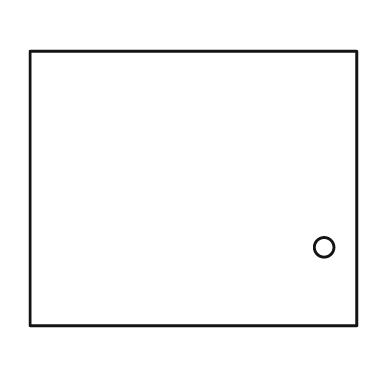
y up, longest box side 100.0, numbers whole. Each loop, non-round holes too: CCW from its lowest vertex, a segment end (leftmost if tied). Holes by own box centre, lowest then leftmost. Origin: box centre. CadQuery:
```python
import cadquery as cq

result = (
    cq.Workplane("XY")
    .moveTo(-50.0, -42.0)
    .lineTo(50.0, -42.0)
    .lineTo(50.0, 42.0)
    .lineTo(-50.0, 42.0)
    .close()
    .moveTo(40.0, -18.0)
    .circle(3.0)
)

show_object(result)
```